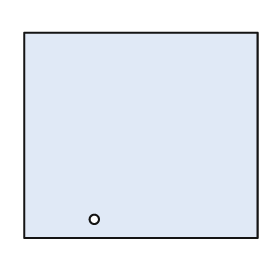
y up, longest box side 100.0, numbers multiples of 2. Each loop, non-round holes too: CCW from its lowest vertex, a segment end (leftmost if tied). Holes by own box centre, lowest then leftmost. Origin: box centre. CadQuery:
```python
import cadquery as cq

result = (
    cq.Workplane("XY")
    .moveTo(-50.0, -44.0)
    .lineTo(50.0, -44.0)
    .lineTo(50.0, 44.0)
    .lineTo(-50.0, 44.0)
    .close()
    .moveTo(-20.0, -36.0)
    .circle(2.0)
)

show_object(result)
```